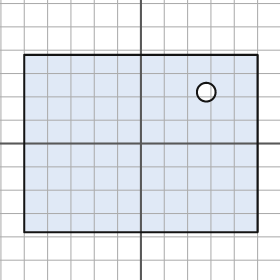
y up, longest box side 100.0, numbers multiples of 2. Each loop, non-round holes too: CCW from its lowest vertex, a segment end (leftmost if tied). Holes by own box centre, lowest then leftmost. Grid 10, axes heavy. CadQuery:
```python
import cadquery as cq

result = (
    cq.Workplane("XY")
    .moveTo(-50.0, -38.0)
    .lineTo(50.0, -38.0)
    .lineTo(50.0, 38.0)
    .lineTo(-50.0, 38.0)
    .close()
    .moveTo(28.0, 22.0)
    .circle(4.0)
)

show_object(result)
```